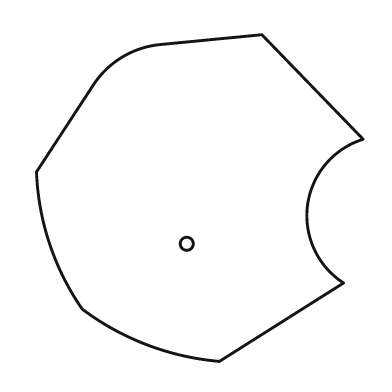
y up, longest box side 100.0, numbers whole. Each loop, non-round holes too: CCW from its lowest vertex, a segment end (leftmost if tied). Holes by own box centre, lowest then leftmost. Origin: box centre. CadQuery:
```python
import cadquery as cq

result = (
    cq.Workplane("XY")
    .moveTo(6.0, -50.0)
    .lineTo(44.0, -26.0)
    .threePointArc((33.0, -2.0), (50.0, 18.0))
    .lineTo(19.0, 50.0)
    .lineTo(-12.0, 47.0)
    .threePointArc((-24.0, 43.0), (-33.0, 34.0))
    .lineTo(-50.0, 8.0)
    .threePointArc((-46.0, -14.0), (-36.0, -34.0))
    .threePointArc((-16.0, -45.0), (6.0, -50.0))
    .close()
    .moveTo(-4.0, -14.0)
    .circle(2.0)
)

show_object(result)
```